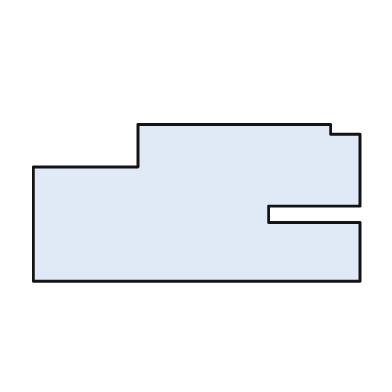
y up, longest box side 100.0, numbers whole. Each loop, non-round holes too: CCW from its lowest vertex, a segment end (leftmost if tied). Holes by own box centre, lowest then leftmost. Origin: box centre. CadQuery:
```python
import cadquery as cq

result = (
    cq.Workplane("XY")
    .moveTo(-50.0, -24.0)
    .lineTo(50.0, -24.0)
    .lineTo(50.0, -6.0)
    .lineTo(22.0, -6.0)
    .lineTo(22.0, -1.0)
    .lineTo(50.0, -1.0)
    .lineTo(50.0, 21.0)
    .lineTo(41.0, 21.0)
    .lineTo(41.0, 24.0)
    .lineTo(-18.0, 24.0)
    .lineTo(-18.0, 11.0)
    .lineTo(-50.0, 11.0)
    .close()
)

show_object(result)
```